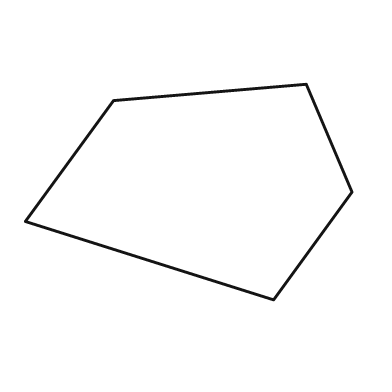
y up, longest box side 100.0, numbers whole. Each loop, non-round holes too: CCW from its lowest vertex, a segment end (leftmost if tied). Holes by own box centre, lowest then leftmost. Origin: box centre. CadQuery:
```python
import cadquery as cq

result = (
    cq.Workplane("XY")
    .moveTo(26.0, -33.0)
    .lineTo(50.0, 0.0)
    .lineTo(36.0, 33.0)
    .lineTo(-23.0, 28.0)
    .lineTo(-50.0, -9.0)
    .close()
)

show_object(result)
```